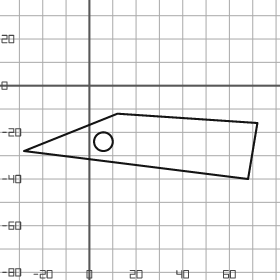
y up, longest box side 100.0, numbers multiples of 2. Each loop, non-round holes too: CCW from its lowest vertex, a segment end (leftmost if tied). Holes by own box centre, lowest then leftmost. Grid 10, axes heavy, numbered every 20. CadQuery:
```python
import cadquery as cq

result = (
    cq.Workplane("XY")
    .moveTo(68.0, -40.0)
    .lineTo(72.0, -16.0)
    .lineTo(12.0, -12.0)
    .lineTo(-28.0, -28.0)
    .close()
    .moveTo(6.0, -24.0)
    .circle(4.0)
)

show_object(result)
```